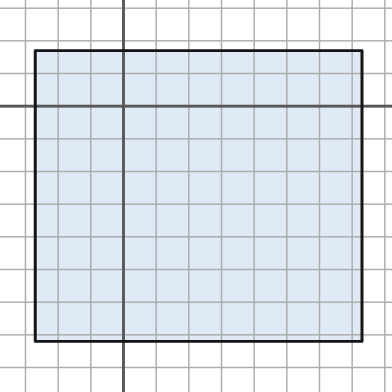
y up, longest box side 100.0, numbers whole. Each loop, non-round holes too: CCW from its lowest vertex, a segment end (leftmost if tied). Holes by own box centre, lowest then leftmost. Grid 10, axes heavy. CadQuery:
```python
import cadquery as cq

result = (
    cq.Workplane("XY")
    .moveTo(-27.0, -72.0)
    .lineTo(73.0, -72.0)
    .lineTo(73.0, 17.0)
    .lineTo(-27.0, 17.0)
    .close()
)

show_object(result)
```